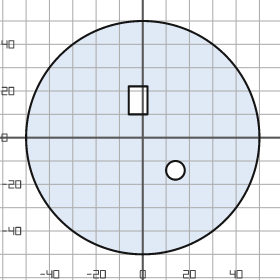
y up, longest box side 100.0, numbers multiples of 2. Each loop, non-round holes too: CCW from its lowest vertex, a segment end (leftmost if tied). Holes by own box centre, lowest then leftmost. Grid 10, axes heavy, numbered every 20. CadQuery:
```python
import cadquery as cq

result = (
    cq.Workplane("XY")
    .moveTo(0.0, 0.0)
    .circle(50.0)
    .moveTo(14.0, -14.0)
    .circle(4.0)
    .moveTo(-6.0, 10.0)
    .lineTo(2.0, 10.0)
    .lineTo(2.0, 22.0)
    .lineTo(-6.0, 22.0)
    .close()
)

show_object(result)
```